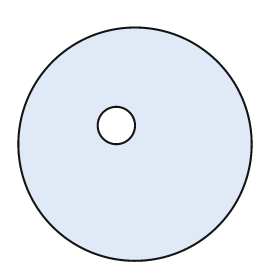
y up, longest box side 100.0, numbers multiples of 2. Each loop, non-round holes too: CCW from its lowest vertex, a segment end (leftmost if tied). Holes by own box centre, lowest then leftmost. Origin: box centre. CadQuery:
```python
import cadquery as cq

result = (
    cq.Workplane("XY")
    .moveTo(0.0, 0.0)
    .circle(50.0)
    .moveTo(-8.0, 8.0)
    .circle(8.0)
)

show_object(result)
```